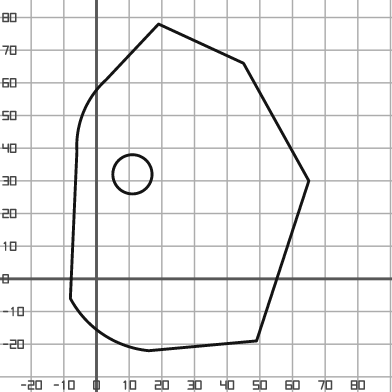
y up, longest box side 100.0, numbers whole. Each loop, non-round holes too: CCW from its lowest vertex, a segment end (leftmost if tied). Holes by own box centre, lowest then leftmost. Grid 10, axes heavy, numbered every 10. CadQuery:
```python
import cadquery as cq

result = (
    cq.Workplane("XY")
    .moveTo(16.0, -22.0)
    .lineTo(49.0, -19.0)
    .lineTo(65.0, 30.0)
    .lineTo(45.0, 66.0)
    .lineTo(19.0, 78.0)
    .lineTo(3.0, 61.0)
    .threePointArc((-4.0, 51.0), (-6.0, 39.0))
    .lineTo(-8.0, -6.0)
    .threePointArc((2.0, -17.0), (16.0, -22.0))
    .close()
    .moveTo(11.0, 32.0)
    .circle(6.0)
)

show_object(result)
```